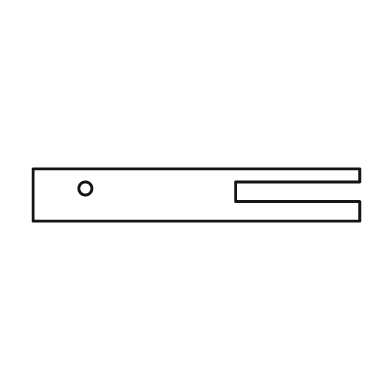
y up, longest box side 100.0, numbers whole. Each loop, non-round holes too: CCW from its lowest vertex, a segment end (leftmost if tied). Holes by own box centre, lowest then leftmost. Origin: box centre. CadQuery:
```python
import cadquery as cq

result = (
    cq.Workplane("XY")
    .moveTo(-50.0, -8.0)
    .lineTo(50.0, -8.0)
    .lineTo(50.0, -2.0)
    .lineTo(12.0, -2.0)
    .lineTo(12.0, 4.0)
    .lineTo(50.0, 4.0)
    .lineTo(50.0, 8.0)
    .lineTo(-50.0, 8.0)
    .close()
    .moveTo(-34.0, 2.0)
    .circle(2.0)
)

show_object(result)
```